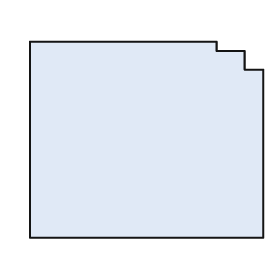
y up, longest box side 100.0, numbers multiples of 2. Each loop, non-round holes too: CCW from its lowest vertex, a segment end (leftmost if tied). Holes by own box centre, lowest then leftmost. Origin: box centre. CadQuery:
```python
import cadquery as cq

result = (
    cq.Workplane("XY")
    .moveTo(-50.0, -42.0)
    .lineTo(50.0, -42.0)
    .lineTo(50.0, 30.0)
    .lineTo(42.0, 30.0)
    .lineTo(42.0, 38.0)
    .lineTo(30.0, 38.0)
    .lineTo(30.0, 42.0)
    .lineTo(-50.0, 42.0)
    .close()
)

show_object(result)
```